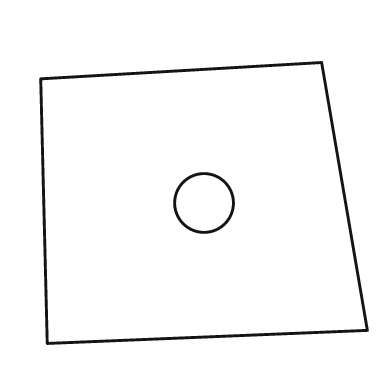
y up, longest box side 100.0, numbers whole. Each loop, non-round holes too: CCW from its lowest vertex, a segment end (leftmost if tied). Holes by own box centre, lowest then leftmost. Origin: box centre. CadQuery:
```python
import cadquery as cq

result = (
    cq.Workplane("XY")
    .moveTo(-48.0, -43.0)
    .lineTo(50.0, -39.0)
    .lineTo(36.0, 43.0)
    .lineTo(-50.0, 38.0)
    .close()
    .moveTo(0.0, 0.0)
    .circle(9.0)
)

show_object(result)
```